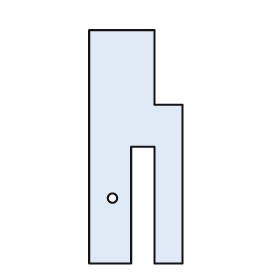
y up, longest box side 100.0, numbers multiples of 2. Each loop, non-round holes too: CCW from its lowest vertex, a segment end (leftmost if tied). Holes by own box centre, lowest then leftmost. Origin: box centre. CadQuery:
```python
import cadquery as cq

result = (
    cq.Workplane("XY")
    .moveTo(-20.0, -50.0)
    .lineTo(-2.0, -50.0)
    .lineTo(-2.0, 0.0)
    .lineTo(8.0, 0.0)
    .lineTo(8.0, -50.0)
    .lineTo(20.0, -50.0)
    .lineTo(20.0, 18.0)
    .lineTo(8.0, 18.0)
    .lineTo(8.0, 50.0)
    .lineTo(-20.0, 50.0)
    .close()
    .moveTo(-10.0, -22.0)
    .circle(2.0)
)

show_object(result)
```